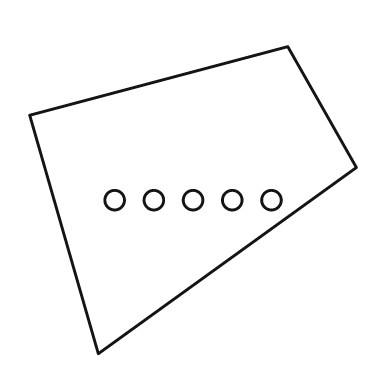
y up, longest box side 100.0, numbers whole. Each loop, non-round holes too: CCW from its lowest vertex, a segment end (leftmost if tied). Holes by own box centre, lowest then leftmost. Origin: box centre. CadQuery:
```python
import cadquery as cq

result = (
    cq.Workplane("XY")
    .moveTo(-29.0, -47.0)
    .lineTo(50.0, 10.0)
    .lineTo(29.0, 47.0)
    .lineTo(-50.0, 26.0)
    .close()
    .moveTo(-24.0, 0.0)
    .circle(3.0)
    .moveTo(-12.0, 0.0)
    .circle(3.0)
    .moveTo(0.0, 0.0)
    .circle(3.0)
    .moveTo(12.0, 0.0)
    .circle(3.0)
    .moveTo(24.0, 0.0)
    .circle(3.0)
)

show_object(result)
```